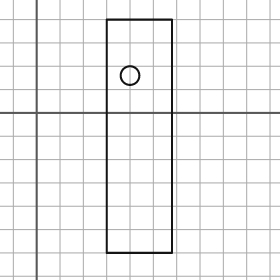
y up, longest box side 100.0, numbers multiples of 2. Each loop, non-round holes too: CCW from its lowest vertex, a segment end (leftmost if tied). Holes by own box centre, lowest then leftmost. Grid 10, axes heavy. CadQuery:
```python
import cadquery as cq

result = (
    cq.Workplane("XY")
    .moveTo(30.0, -60.0)
    .lineTo(58.0, -60.0)
    .lineTo(58.0, 40.0)
    .lineTo(30.0, 40.0)
    .close()
    .moveTo(40.0, 16.0)
    .circle(4.0)
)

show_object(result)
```